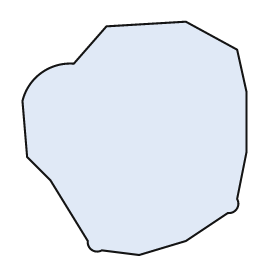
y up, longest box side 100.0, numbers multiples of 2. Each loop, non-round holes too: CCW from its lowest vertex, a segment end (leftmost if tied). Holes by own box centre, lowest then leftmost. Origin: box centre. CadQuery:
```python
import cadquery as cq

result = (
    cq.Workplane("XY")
    .moveTo(2.0, -50.0)
    .lineTo(22.0, -44.0)
    .lineTo(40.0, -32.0)
    .threePointArc((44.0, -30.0), (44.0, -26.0))
    .lineTo(48.0, -6.0)
    .lineTo(48.0, 20.0)
    .lineTo(44.0, 38.0)
    .lineTo(22.0, 50.0)
    .lineTo(-12.0, 48.0)
    .lineTo(-26.0, 32.0)
    .threePointArc((-40.0, 28.0), (-48.0, 16.0))
    .lineTo(-46.0, -8.0)
    .lineTo(-36.0, -18.0)
    .lineTo(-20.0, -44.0)
    .threePointArc((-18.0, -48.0), (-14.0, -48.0))
    .close()
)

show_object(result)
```